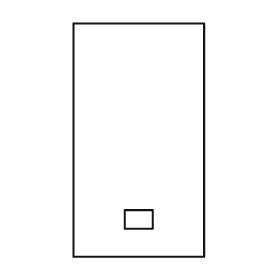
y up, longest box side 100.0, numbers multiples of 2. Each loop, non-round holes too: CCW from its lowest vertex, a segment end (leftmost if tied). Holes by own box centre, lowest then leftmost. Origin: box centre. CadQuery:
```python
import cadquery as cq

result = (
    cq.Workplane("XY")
    .moveTo(-28.0, -50.0)
    .lineTo(28.0, -50.0)
    .lineTo(28.0, 50.0)
    .lineTo(-28.0, 50.0)
    .close()
    .moveTo(-6.0, -38.0)
    .lineTo(6.0, -38.0)
    .lineTo(6.0, -30.0)
    .lineTo(-6.0, -30.0)
    .close()
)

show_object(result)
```